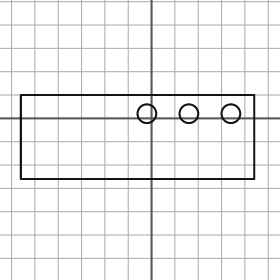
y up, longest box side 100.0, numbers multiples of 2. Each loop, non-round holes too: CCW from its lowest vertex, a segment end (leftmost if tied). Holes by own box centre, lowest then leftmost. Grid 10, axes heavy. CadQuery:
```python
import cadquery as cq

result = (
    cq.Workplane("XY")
    .moveTo(-56.0, -26.0)
    .lineTo(44.0, -26.0)
    .lineTo(44.0, 10.0)
    .lineTo(-56.0, 10.0)
    .close()
    .moveTo(-2.0, 2.0)
    .circle(4.0)
    .moveTo(16.0, 2.0)
    .circle(4.0)
    .moveTo(34.0, 2.0)
    .circle(4.0)
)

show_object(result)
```